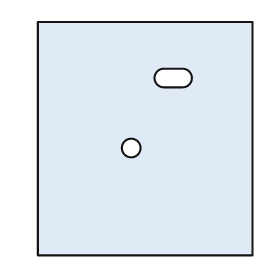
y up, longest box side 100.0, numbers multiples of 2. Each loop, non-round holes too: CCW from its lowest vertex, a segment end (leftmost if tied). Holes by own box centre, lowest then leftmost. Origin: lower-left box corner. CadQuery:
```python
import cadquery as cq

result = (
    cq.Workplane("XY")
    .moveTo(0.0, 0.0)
    .lineTo(92.0, 0.0)
    .lineTo(92.0, 100.0)
    .lineTo(0.0, 100.0)
    .close()
    .moveTo(40.0, 46.0)
    .circle(4.0)
    .moveTo(54.0, 72.0)
    .lineTo(62.0, 72.0)
    .threePointArc((66.0, 76.0), (62.0, 80.0))
    .lineTo(54.0, 80.0)
    .threePointArc((50.0, 76.0), (54.0, 72.0))
    .close()
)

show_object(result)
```